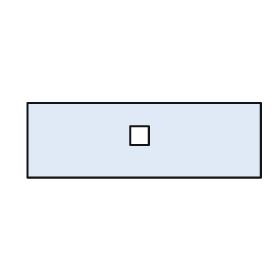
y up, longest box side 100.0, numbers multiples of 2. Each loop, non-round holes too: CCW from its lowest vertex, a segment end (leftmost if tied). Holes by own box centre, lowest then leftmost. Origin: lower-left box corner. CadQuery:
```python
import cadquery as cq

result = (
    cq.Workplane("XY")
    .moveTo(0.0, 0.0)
    .lineTo(100.0, 0.0)
    .lineTo(100.0, 32.0)
    .lineTo(0.0, 32.0)
    .close()
    .moveTo(44.0, 14.0)
    .lineTo(52.0, 14.0)
    .lineTo(52.0, 22.0)
    .lineTo(44.0, 22.0)
    .close()
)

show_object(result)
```